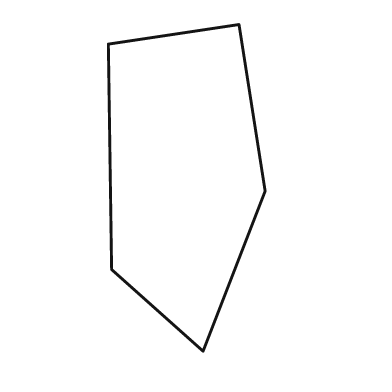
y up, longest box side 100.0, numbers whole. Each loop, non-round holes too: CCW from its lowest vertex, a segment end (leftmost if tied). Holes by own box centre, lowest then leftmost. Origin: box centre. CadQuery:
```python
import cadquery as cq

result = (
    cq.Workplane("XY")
    .moveTo(5.0, -50.0)
    .lineTo(24.0, -1.0)
    .lineTo(16.0, 50.0)
    .lineTo(-24.0, 44.0)
    .lineTo(-23.0, -25.0)
    .close()
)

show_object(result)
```